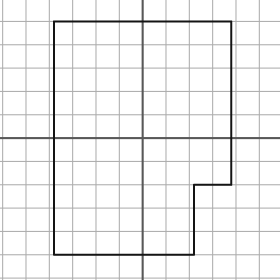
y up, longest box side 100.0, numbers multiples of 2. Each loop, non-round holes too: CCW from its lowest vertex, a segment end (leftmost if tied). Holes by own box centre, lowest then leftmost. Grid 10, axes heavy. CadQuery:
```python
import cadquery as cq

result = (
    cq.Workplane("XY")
    .moveTo(-38.0, -50.0)
    .lineTo(22.0, -50.0)
    .lineTo(22.0, -20.0)
    .lineTo(38.0, -20.0)
    .lineTo(38.0, 50.0)
    .lineTo(-38.0, 50.0)
    .close()
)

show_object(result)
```